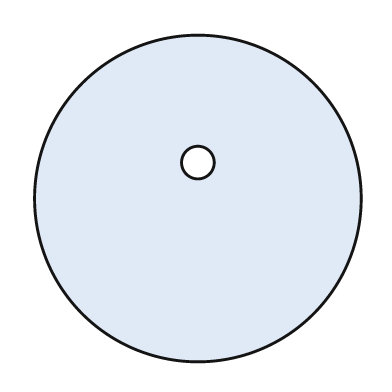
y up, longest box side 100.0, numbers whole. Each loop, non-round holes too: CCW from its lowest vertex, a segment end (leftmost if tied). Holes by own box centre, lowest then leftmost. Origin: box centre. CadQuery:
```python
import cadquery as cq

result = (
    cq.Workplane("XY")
    .moveTo(0.0, 0.0)
    .circle(50.0)
    .moveTo(0.0, 11.0)
    .circle(5.0)
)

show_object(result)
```